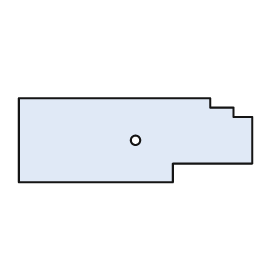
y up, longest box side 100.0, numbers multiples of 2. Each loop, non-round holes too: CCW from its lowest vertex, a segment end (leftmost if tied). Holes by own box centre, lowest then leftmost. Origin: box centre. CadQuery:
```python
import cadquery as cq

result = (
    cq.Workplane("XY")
    .moveTo(-50.0, -18.0)
    .lineTo(16.0, -18.0)
    .lineTo(16.0, -10.0)
    .lineTo(50.0, -10.0)
    .lineTo(50.0, 10.0)
    .lineTo(42.0, 10.0)
    .lineTo(42.0, 14.0)
    .lineTo(32.0, 14.0)
    .lineTo(32.0, 18.0)
    .lineTo(-50.0, 18.0)
    .close()
    .moveTo(0.0, 0.0)
    .circle(2.0)
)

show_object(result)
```